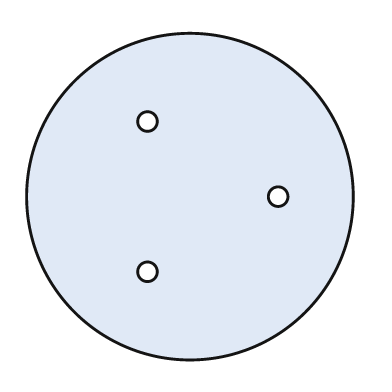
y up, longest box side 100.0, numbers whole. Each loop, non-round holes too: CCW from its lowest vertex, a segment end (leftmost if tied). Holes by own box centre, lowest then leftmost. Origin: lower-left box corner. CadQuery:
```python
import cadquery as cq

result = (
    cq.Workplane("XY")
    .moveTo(50.0, 50.0)
    .circle(50.0)
    .moveTo(37.0, 27.0)
    .circle(3.0)
    .moveTo(77.0, 50.0)
    .circle(3.0)
    .moveTo(37.0, 73.0)
    .circle(3.0)
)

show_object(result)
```